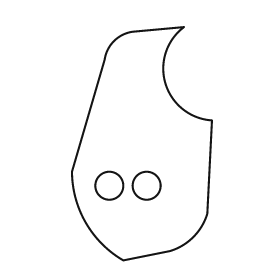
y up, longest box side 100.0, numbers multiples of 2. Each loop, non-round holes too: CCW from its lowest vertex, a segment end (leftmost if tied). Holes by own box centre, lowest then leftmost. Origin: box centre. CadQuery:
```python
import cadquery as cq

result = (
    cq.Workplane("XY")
    .moveTo(-8.0, -50.0)
    .lineTo(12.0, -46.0)
    .threePointArc((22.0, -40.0), (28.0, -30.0))
    .lineTo(30.0, 10.0)
    .threePointArc((10.0, 26.0), (18.0, 50.0))
    .lineTo(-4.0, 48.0)
    .threePointArc((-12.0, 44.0), (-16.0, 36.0))
    .lineTo(-30.0, -12.0)
    .threePointArc((-24.0, -34.0), (-8.0, -50.0))
    .close()
    .moveTo(-14.0, -18.0)
    .circle(6.0)
    .moveTo(2.0, -18.0)
    .circle(6.0)
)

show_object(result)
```